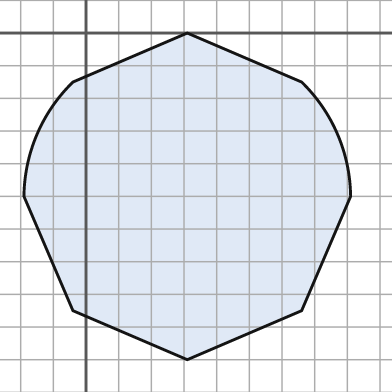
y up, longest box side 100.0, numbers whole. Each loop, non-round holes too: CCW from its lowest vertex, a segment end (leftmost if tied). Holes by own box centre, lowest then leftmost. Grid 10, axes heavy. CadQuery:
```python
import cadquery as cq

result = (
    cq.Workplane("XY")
    .moveTo(31.0, -100.0)
    .lineTo(66.0, -85.0)
    .lineTo(81.0, -50.0)
    .threePointArc((77.0, -31.0), (66.0, -15.0))
    .lineTo(31.0, 0.0)
    .lineTo(-4.0, -15.0)
    .threePointArc((-15.0, -31.0), (-19.0, -50.0))
    .lineTo(-4.0, -85.0)
    .close()
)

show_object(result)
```